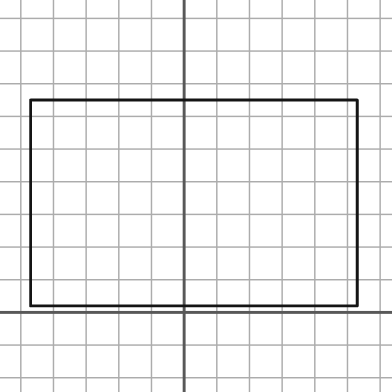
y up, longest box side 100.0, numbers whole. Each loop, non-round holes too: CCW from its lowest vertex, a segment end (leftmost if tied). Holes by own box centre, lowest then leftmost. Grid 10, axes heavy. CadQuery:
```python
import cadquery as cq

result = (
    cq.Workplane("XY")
    .moveTo(-47.0, 2.0)
    .lineTo(53.0, 2.0)
    .lineTo(53.0, 65.0)
    .lineTo(-47.0, 65.0)
    .close()
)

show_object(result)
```